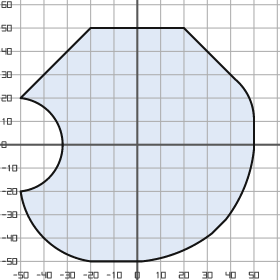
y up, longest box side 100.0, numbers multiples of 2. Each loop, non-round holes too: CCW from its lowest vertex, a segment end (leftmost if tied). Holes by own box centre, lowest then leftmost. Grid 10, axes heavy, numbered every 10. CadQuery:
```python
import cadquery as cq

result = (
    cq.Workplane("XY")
    .moveTo(-20.0, -50.0)
    .lineTo(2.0, -50.0)
    .threePointArc((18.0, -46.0), (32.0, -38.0))
    .lineTo(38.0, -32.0)
    .threePointArc((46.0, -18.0), (50.0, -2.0))
    .lineTo(50.0, 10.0)
    .threePointArc((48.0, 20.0), (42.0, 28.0))
    .lineTo(20.0, 50.0)
    .lineTo(-20.0, 50.0)
    .lineTo(-50.0, 20.0)
    .threePointArc((-32.0, 0.0), (-50.0, -20.0))
    .threePointArc((-40.0, -40.0), (-20.0, -50.0))
    .close()
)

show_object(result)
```